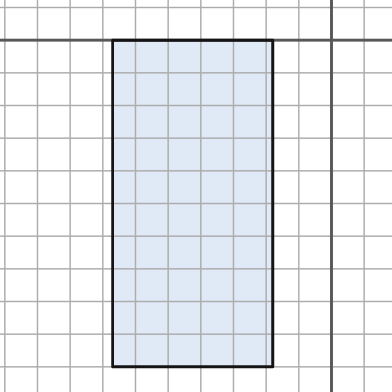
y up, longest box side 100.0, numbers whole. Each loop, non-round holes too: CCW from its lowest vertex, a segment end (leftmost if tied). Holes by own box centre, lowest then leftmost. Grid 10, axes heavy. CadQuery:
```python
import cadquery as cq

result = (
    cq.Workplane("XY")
    .moveTo(-67.0, -100.0)
    .lineTo(-18.0, -100.0)
    .lineTo(-18.0, 0.0)
    .lineTo(-67.0, 0.0)
    .close()
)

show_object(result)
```